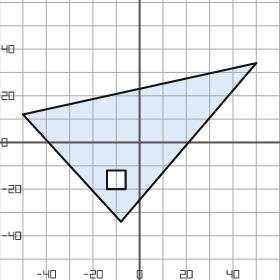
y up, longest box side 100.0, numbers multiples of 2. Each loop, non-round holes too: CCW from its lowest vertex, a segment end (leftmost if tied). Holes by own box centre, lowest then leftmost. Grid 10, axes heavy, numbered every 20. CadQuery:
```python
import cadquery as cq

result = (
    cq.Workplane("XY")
    .moveTo(-8.0, -34.0)
    .lineTo(50.0, 34.0)
    .lineTo(-50.0, 12.0)
    .close()
    .moveTo(-14.0, -20.0)
    .lineTo(-6.0, -20.0)
    .lineTo(-6.0, -12.0)
    .lineTo(-14.0, -12.0)
    .close()
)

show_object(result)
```